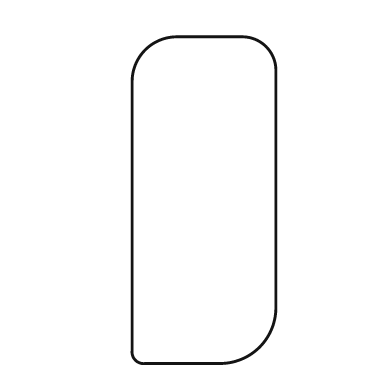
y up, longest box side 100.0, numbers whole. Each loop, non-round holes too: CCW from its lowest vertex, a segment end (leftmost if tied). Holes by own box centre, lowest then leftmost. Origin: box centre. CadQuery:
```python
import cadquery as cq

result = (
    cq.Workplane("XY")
    .moveTo(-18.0, -50.0)
    .lineTo(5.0, -50.0)
    .threePointArc((17.0, -45.0), (22.0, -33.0))
    .lineTo(22.0, 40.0)
    .threePointArc((19.0, 47.0), (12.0, 50.0))
    .lineTo(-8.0, 50.0)
    .threePointArc((-18.0, 46.0), (-22.0, 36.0))
    .lineTo(-22.0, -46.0)
    .threePointArc((-21.0, -49.0), (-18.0, -50.0))
    .close()
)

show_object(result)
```